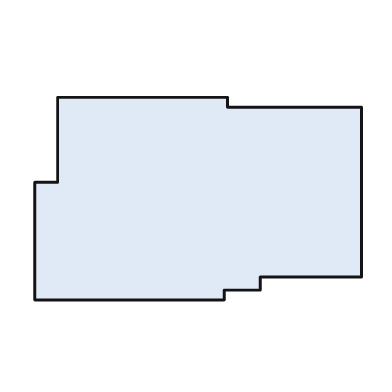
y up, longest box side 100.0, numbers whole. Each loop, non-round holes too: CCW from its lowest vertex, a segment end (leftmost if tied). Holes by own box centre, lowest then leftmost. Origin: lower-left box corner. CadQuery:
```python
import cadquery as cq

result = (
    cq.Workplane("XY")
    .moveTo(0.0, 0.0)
    .lineTo(58.0, 0.0)
    .lineTo(58.0, 3.0)
    .lineTo(69.0, 3.0)
    .lineTo(69.0, 7.0)
    .lineTo(100.0, 7.0)
    .lineTo(100.0, 59.0)
    .lineTo(59.0, 59.0)
    .lineTo(59.0, 62.0)
    .lineTo(7.0, 62.0)
    .lineTo(7.0, 36.0)
    .lineTo(0.0, 36.0)
    .close()
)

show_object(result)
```